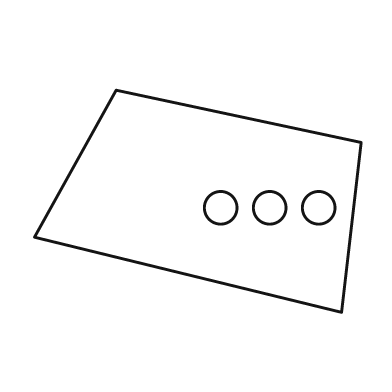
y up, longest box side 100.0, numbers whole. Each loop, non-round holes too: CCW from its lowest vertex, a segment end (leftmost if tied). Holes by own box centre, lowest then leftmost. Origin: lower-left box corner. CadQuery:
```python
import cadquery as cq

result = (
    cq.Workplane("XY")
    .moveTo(94.0, 0.0)
    .lineTo(100.0, 52.0)
    .lineTo(25.0, 68.0)
    .lineTo(0.0, 23.0)
    .close()
    .moveTo(57.0, 32.0)
    .circle(5.0)
    .moveTo(72.0, 32.0)
    .circle(5.0)
    .moveTo(87.0, 32.0)
    .circle(5.0)
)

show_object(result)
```